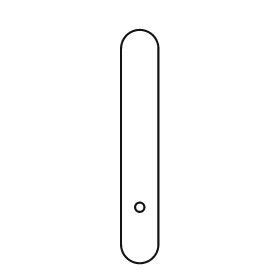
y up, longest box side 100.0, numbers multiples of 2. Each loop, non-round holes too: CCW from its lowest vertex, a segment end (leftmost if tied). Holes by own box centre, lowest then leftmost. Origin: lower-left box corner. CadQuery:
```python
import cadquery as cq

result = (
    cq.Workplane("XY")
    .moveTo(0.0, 8.0)
    .threePointArc((8.0, 0.0), (16.0, 8.0))
    .lineTo(16.0, 92.0)
    .threePointArc((8.0, 100.0), (0.0, 92.0))
    .close()
    .moveTo(8.0, 24.0)
    .circle(2.0)
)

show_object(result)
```